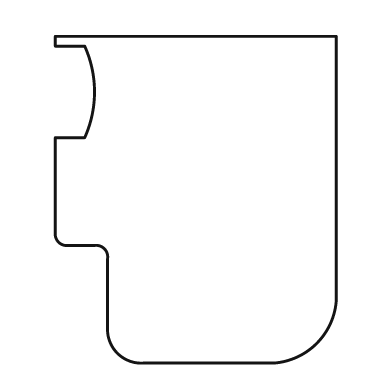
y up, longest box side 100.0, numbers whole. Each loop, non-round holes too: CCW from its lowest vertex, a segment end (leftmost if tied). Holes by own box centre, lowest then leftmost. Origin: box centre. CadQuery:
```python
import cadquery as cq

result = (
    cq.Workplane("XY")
    .moveTo(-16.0, -50.0)
    .lineTo(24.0, -50.0)
    .threePointArc((37.0, -44.0), (43.0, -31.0))
    .lineTo(43.0, 50.0)
    .lineTo(-43.0, 50.0)
    .lineTo(-43.0, 47.0)
    .lineTo(-34.0, 47.0)
    .threePointArc((-31.0, 33.0), (-34.0, 19.0))
    .lineTo(-43.0, 19.0)
    .lineTo(-43.0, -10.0)
    .threePointArc((-42.0, -13.0), (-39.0, -14.0))
    .lineTo(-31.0, -14.0)
    .threePointArc((-28.0, -15.0), (-27.0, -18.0))
    .lineTo(-27.0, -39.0)
    .threePointArc((-24.0, -47.0), (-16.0, -50.0))
    .close()
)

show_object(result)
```